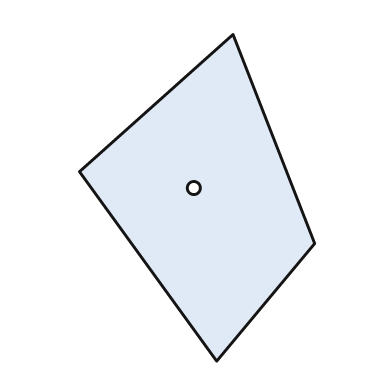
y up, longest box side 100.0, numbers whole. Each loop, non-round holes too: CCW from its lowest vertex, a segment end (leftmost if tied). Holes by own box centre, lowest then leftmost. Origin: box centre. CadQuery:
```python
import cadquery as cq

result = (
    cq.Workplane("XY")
    .moveTo(6.0, -50.0)
    .lineTo(36.0, -14.0)
    .lineTo(11.0, 50.0)
    .lineTo(-36.0, 8.0)
    .close()
    .moveTo(-1.0, 3.0)
    .circle(2.0)
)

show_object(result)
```